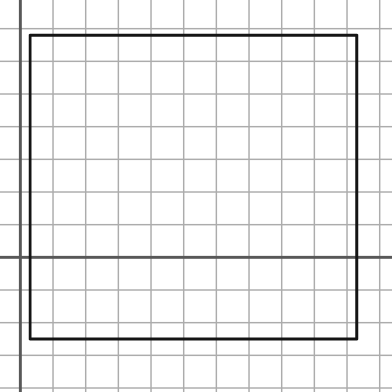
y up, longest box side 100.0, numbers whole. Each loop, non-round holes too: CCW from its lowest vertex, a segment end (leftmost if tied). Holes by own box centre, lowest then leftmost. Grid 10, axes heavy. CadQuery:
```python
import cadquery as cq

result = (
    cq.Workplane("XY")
    .moveTo(3.0, -25.0)
    .lineTo(103.0, -25.0)
    .lineTo(103.0, 68.0)
    .lineTo(3.0, 68.0)
    .close()
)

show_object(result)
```